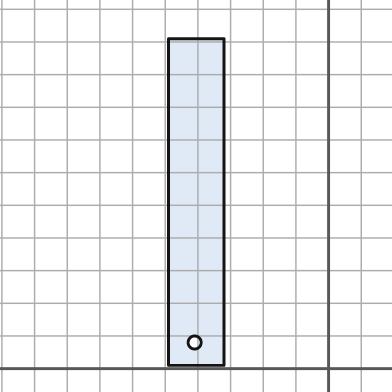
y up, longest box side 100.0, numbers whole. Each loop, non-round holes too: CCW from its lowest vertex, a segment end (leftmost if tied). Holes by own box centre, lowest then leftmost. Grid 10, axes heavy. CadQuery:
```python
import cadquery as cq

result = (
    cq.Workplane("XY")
    .moveTo(-49.0, 1.0)
    .lineTo(-32.0, 1.0)
    .lineTo(-32.0, 101.0)
    .lineTo(-49.0, 101.0)
    .close()
    .moveTo(-41.0, 8.0)
    .circle(2.0)
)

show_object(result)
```